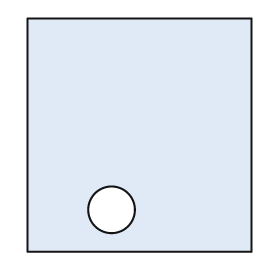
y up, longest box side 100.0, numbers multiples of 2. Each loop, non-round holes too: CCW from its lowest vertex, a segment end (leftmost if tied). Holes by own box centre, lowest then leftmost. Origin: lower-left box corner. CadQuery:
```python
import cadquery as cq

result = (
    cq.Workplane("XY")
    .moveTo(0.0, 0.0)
    .lineTo(96.0, 0.0)
    .lineTo(96.0, 100.0)
    .lineTo(0.0, 100.0)
    .close()
    .moveTo(36.0, 18.0)
    .circle(10.0)
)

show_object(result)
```